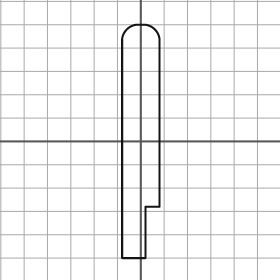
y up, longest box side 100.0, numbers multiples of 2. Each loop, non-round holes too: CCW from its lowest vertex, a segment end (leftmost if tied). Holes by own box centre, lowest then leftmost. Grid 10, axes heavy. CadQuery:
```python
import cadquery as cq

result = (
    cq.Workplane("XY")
    .moveTo(-8.0, -50.0)
    .lineTo(2.0, -50.0)
    .lineTo(2.0, -28.0)
    .lineTo(8.0, -28.0)
    .lineTo(8.0, 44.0)
    .threePointArc((6.0, 48.0), (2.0, 50.0))
    .lineTo(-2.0, 50.0)
    .threePointArc((-6.0, 48.0), (-8.0, 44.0))
    .close()
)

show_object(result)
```